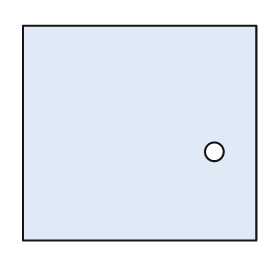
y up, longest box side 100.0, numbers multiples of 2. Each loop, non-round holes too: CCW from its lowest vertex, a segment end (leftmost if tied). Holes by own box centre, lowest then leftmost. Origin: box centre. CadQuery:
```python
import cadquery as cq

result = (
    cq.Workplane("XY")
    .moveTo(-50.0, -46.0)
    .lineTo(50.0, -46.0)
    .lineTo(50.0, 46.0)
    .lineTo(-50.0, 46.0)
    .close()
    .moveTo(32.0, -8.0)
    .circle(4.0)
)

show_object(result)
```